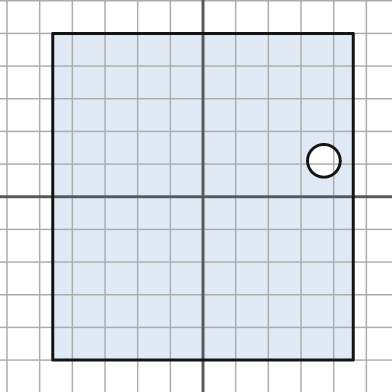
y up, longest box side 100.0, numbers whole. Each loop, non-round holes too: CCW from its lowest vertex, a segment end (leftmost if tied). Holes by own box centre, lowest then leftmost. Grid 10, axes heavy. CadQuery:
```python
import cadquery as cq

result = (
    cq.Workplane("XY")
    .moveTo(-46.0, -50.0)
    .lineTo(46.0, -50.0)
    .lineTo(46.0, 50.0)
    .lineTo(-46.0, 50.0)
    .close()
    .moveTo(37.0, 11.0)
    .circle(5.0)
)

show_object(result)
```